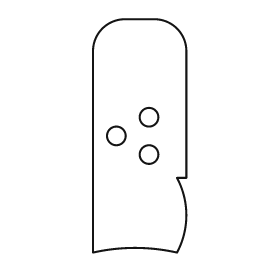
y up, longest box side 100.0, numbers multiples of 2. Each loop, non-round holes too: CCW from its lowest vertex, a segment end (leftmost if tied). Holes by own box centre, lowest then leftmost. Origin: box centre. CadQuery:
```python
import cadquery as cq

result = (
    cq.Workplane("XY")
    .moveTo(-20.0, -50.0)
    .threePointArc((-2.0, -48.0), (16.0, -50.0))
    .threePointArc((20.0, -34.0), (16.0, -18.0))
    .lineTo(20.0, -18.0)
    .lineTo(20.0, 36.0)
    .threePointArc((16.0, 46.0), (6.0, 50.0))
    .lineTo(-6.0, 50.0)
    .threePointArc((-16.0, 46.0), (-20.0, 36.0))
    .close()
    .moveTo(4.0, -8.0)
    .circle(4.0)
    .moveTo(-10.0, 0.0)
    .circle(4.0)
    .moveTo(4.0, 8.0)
    .circle(4.0)
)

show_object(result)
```